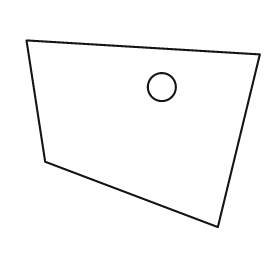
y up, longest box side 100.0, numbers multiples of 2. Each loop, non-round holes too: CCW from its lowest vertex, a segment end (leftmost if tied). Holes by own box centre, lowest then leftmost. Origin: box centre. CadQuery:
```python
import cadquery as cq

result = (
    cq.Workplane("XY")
    .moveTo(32.0, -40.0)
    .lineTo(50.0, 34.0)
    .lineTo(-50.0, 40.0)
    .lineTo(-42.0, -12.0)
    .close()
    .moveTo(8.0, 20.0)
    .circle(6.0)
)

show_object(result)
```